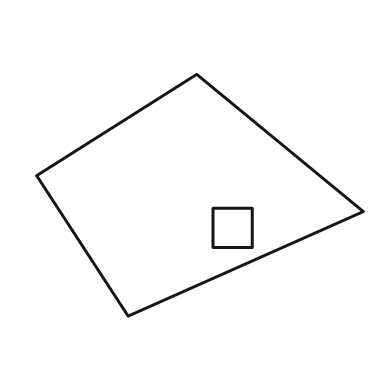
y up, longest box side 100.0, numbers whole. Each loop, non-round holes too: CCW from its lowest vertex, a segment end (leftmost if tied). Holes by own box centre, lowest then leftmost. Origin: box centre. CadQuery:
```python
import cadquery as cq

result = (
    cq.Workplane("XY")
    .moveTo(-22.0, -37.0)
    .lineTo(50.0, -5.0)
    .lineTo(-1.0, 37.0)
    .lineTo(-50.0, 6.0)
    .close()
    .moveTo(4.0, -16.0)
    .lineTo(16.0, -16.0)
    .lineTo(16.0, -4.0)
    .lineTo(4.0, -4.0)
    .close()
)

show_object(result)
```